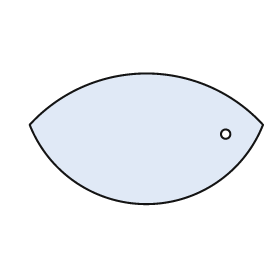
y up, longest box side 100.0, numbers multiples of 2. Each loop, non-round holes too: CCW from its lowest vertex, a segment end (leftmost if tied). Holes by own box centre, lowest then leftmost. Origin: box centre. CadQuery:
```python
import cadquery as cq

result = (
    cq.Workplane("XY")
    .moveTo(-50.0, 6.0)
    .threePointArc((0.0, -28.0), (50.0, 6.0))
    .threePointArc((0.0, 28.0), (-50.0, 6.0))
    .close()
    .moveTo(34.0, 2.0)
    .circle(2.0)
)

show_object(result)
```